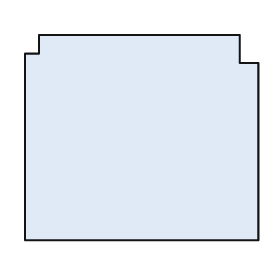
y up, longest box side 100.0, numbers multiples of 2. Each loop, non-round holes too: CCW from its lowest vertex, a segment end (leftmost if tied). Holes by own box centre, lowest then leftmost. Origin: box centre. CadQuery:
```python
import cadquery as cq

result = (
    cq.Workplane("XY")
    .moveTo(-50.0, -44.0)
    .lineTo(50.0, -44.0)
    .lineTo(50.0, 32.0)
    .lineTo(42.0, 32.0)
    .lineTo(42.0, 44.0)
    .lineTo(-44.0, 44.0)
    .lineTo(-44.0, 36.0)
    .lineTo(-50.0, 36.0)
    .close()
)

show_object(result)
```